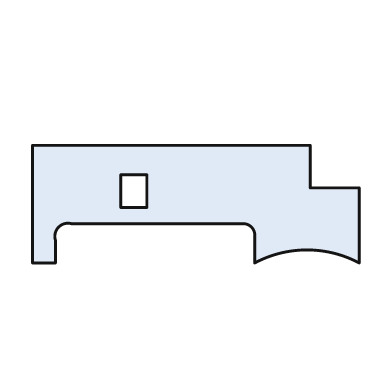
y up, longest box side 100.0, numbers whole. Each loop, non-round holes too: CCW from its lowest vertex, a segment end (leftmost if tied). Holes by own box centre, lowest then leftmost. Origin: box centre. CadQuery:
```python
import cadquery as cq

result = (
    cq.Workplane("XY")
    .moveTo(-50.0, -18.0)
    .lineTo(-43.0, -18.0)
    .lineTo(-43.0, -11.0)
    .threePointArc((-42.0, -7.0), (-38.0, -6.0))
    .lineTo(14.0, -6.0)
    .threePointArc((17.0, -7.0), (18.0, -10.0))
    .lineTo(18.0, -18.0)
    .threePointArc((34.0, -14.0), (50.0, -18.0))
    .lineTo(50.0, 5.0)
    .lineTo(35.0, 5.0)
    .lineTo(35.0, 18.0)
    .lineTo(-50.0, 18.0)
    .close()
    .moveTo(-23.0, -1.0)
    .lineTo(-15.0, -1.0)
    .lineTo(-15.0, 9.0)
    .lineTo(-23.0, 9.0)
    .close()
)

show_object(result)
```